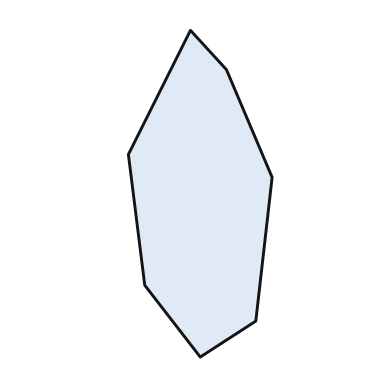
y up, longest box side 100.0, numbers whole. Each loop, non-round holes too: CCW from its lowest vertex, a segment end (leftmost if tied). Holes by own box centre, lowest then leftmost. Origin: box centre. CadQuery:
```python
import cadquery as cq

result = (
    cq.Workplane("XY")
    .moveTo(0.0, -50.0)
    .lineTo(17.0, -39.0)
    .lineTo(22.0, 5.0)
    .lineTo(8.0, 38.0)
    .lineTo(-3.0, 50.0)
    .lineTo(-22.0, 12.0)
    .lineTo(-17.0, -28.0)
    .close()
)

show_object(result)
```